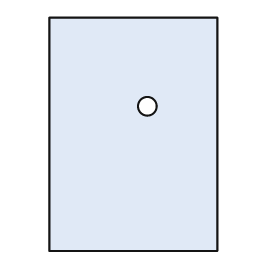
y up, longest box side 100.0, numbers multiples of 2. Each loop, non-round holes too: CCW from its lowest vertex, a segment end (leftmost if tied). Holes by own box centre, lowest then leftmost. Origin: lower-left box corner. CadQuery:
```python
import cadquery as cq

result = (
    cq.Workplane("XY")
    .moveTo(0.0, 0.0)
    .lineTo(72.0, 0.0)
    .lineTo(72.0, 100.0)
    .lineTo(0.0, 100.0)
    .close()
    .moveTo(42.0, 62.0)
    .circle(4.0)
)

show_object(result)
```